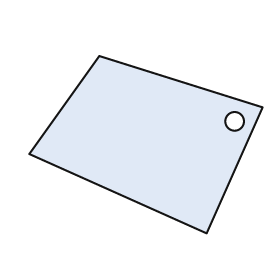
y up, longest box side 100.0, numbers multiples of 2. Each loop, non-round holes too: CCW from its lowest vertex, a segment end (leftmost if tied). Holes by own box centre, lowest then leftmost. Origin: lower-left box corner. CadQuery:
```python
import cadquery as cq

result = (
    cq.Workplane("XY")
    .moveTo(76.0, 0.0)
    .lineTo(100.0, 54.0)
    .lineTo(30.0, 76.0)
    .lineTo(0.0, 34.0)
    .close()
    .moveTo(88.0, 48.0)
    .circle(4.0)
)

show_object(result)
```